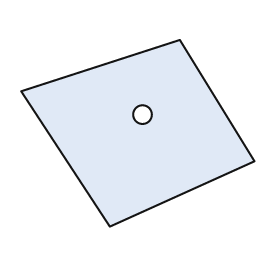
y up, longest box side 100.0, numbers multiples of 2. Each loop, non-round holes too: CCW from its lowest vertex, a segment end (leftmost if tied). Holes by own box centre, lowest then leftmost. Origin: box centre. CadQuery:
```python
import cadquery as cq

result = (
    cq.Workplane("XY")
    .moveTo(-12.0, -40.0)
    .lineTo(50.0, -12.0)
    .lineTo(18.0, 40.0)
    .lineTo(-50.0, 18.0)
    .close()
    .moveTo(2.0, 8.0)
    .circle(4.0)
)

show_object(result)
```